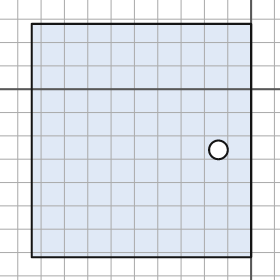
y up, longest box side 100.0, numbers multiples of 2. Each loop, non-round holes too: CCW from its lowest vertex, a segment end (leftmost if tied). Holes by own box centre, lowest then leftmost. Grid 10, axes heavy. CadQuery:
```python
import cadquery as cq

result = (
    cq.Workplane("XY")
    .moveTo(-94.0, -72.0)
    .lineTo(0.0, -72.0)
    .lineTo(0.0, 28.0)
    .lineTo(-94.0, 28.0)
    .close()
    .moveTo(-14.0, -26.0)
    .circle(4.0)
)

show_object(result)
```